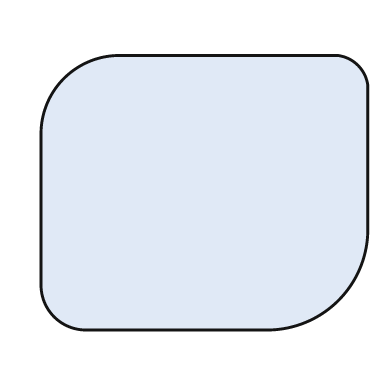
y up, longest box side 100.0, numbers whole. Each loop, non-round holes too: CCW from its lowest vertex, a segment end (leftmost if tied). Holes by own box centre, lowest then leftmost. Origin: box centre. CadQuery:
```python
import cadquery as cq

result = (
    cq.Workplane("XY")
    .moveTo(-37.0, -42.0)
    .lineTo(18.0, -42.0)
    .threePointArc((41.0, -33.0), (50.0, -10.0))
    .lineTo(50.0, 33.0)
    .threePointArc((47.0, 39.0), (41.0, 42.0))
    .lineTo(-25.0, 42.0)
    .threePointArc((-43.0, 35.0), (-50.0, 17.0))
    .lineTo(-50.0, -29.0)
    .threePointArc((-46.0, -38.0), (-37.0, -42.0))
    .close()
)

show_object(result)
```